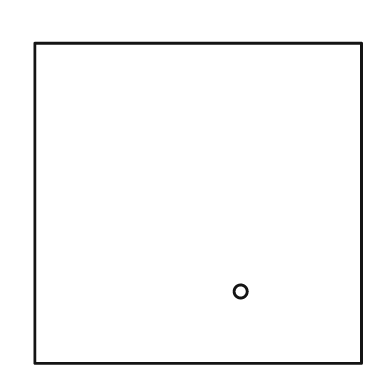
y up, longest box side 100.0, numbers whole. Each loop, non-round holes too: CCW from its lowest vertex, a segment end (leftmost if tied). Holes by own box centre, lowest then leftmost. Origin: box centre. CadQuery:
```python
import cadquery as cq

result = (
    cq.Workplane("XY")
    .moveTo(-50.0, -49.0)
    .lineTo(50.0, -49.0)
    .lineTo(50.0, 49.0)
    .lineTo(-50.0, 49.0)
    .close()
    .moveTo(13.0, -27.0)
    .circle(2.0)
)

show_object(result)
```